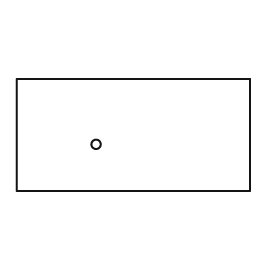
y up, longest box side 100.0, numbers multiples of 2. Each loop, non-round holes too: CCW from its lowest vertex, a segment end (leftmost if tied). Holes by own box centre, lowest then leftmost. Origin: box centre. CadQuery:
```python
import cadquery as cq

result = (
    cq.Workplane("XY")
    .moveTo(-50.0, -24.0)
    .lineTo(50.0, -24.0)
    .lineTo(50.0, 24.0)
    .lineTo(-50.0, 24.0)
    .close()
    .moveTo(-16.0, -4.0)
    .circle(2.0)
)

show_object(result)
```